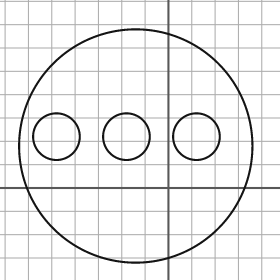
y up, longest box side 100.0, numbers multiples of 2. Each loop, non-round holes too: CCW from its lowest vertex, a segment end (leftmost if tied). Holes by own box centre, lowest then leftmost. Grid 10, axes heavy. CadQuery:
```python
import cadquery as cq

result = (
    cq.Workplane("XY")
    .moveTo(-14.0, 18.0)
    .circle(50.0)
    .moveTo(-48.0, 22.0)
    .circle(10.0)
    .moveTo(-18.0, 22.0)
    .circle(10.0)
    .moveTo(12.0, 22.0)
    .circle(10.0)
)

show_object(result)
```